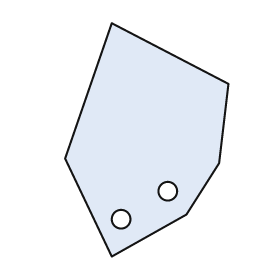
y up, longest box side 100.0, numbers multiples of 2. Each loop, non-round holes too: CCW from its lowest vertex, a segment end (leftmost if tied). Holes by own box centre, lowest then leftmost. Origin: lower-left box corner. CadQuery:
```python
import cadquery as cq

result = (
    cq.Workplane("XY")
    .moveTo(20.0, 0.0)
    .lineTo(52.0, 18.0)
    .lineTo(66.0, 40.0)
    .lineTo(70.0, 74.0)
    .lineTo(20.0, 100.0)
    .lineTo(0.0, 42.0)
    .close()
    .moveTo(24.0, 16.0)
    .circle(4.0)
    .moveTo(44.0, 28.0)
    .circle(4.0)
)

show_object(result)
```